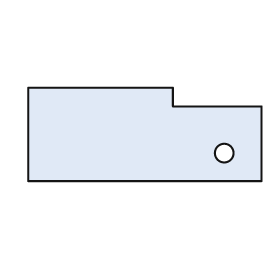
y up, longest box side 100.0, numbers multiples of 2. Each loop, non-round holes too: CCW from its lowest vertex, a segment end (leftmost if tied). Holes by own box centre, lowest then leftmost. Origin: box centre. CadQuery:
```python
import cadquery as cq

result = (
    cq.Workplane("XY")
    .moveTo(-50.0, -20.0)
    .lineTo(50.0, -20.0)
    .lineTo(50.0, 12.0)
    .lineTo(12.0, 12.0)
    .lineTo(12.0, 20.0)
    .lineTo(-50.0, 20.0)
    .close()
    .moveTo(34.0, -8.0)
    .circle(4.0)
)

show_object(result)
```